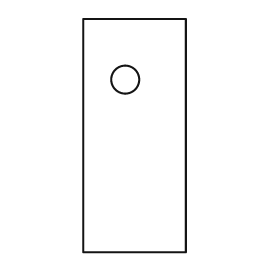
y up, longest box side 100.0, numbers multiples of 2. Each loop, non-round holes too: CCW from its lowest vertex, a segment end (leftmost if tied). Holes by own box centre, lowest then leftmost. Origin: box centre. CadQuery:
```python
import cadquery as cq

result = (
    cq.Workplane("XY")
    .moveTo(-22.0, -50.0)
    .lineTo(22.0, -50.0)
    .lineTo(22.0, 50.0)
    .lineTo(-22.0, 50.0)
    .close()
    .moveTo(-4.0, 24.0)
    .circle(6.0)
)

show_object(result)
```